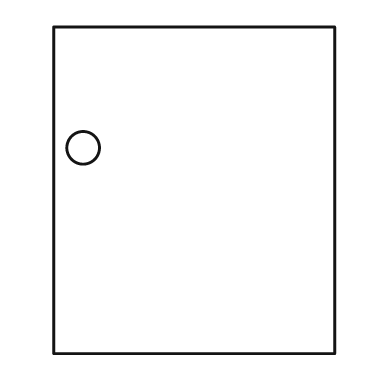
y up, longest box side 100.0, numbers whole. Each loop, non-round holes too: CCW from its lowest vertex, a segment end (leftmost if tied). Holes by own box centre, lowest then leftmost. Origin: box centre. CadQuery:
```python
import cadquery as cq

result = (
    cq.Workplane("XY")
    .moveTo(-43.0, -50.0)
    .lineTo(43.0, -50.0)
    .lineTo(43.0, 50.0)
    .lineTo(-43.0, 50.0)
    .close()
    .moveTo(-34.0, 13.0)
    .circle(5.0)
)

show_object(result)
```